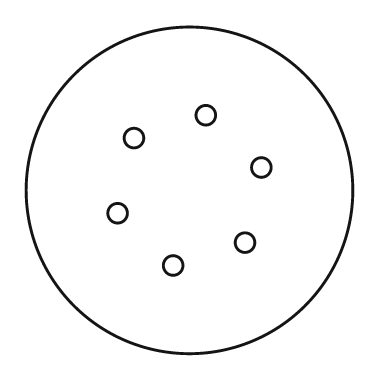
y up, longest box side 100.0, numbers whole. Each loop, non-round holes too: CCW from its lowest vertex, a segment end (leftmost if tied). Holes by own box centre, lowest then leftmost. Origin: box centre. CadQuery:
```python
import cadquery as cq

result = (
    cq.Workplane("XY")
    .moveTo(0.0, 0.0)
    .circle(50.0)
    .moveTo(-5.0, -23.0)
    .circle(3.0)
    .moveTo(17.0, -16.0)
    .circle(3.0)
    .moveTo(-22.0, -7.0)
    .circle(3.0)
    .moveTo(22.0, 7.0)
    .circle(3.0)
    .moveTo(-17.0, 16.0)
    .circle(3.0)
    .moveTo(5.0, 23.0)
    .circle(3.0)
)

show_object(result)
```